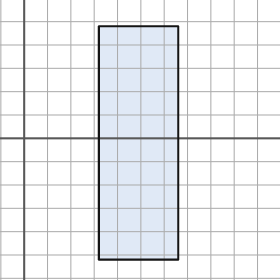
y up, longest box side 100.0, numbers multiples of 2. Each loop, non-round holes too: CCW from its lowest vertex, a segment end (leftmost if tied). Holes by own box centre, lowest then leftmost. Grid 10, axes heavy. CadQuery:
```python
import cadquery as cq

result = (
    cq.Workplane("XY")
    .moveTo(32.0, -52.0)
    .lineTo(66.0, -52.0)
    .lineTo(66.0, 48.0)
    .lineTo(32.0, 48.0)
    .close()
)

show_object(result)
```